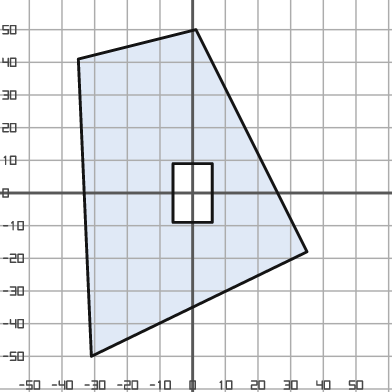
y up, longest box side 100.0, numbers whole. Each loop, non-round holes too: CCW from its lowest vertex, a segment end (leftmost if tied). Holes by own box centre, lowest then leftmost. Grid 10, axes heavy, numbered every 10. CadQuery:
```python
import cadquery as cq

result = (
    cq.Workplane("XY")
    .moveTo(-31.0, -50.0)
    .lineTo(35.0, -18.0)
    .lineTo(1.0, 50.0)
    .lineTo(-35.0, 41.0)
    .close()
    .moveTo(-6.0, -9.0)
    .lineTo(6.0, -9.0)
    .lineTo(6.0, 9.0)
    .lineTo(-6.0, 9.0)
    .close()
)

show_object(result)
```